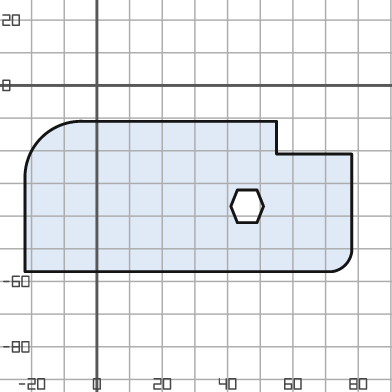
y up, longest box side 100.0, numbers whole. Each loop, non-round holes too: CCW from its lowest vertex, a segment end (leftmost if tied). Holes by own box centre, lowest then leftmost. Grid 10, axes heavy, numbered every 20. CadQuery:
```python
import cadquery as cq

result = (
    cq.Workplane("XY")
    .moveTo(-22.0, -57.0)
    .lineTo(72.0, -57.0)
    .threePointArc((76.0, -55.0), (78.0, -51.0))
    .lineTo(78.0, -21.0)
    .lineTo(55.0, -21.0)
    .lineTo(55.0, -11.0)
    .lineTo(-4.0, -11.0)
    .threePointArc((-17.0, -16.0), (-22.0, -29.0))
    .close()
    .moveTo(43.0, -42.0)
    .lineTo(49.0, -42.0)
    .lineTo(51.0, -37.0)
    .lineTo(49.0, -32.0)
    .lineTo(43.0, -32.0)
    .lineTo(41.0, -37.0)
    .close()
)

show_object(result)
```